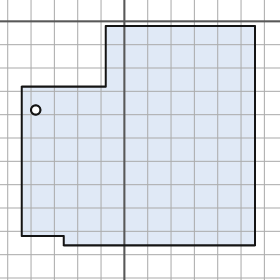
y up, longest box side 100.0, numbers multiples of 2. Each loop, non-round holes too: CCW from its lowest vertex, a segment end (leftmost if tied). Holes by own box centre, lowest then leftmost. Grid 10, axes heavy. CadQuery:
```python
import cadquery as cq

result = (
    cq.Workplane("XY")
    .moveTo(-26.0, -96.0)
    .lineTo(56.0, -96.0)
    .lineTo(56.0, -2.0)
    .lineTo(-8.0, -2.0)
    .lineTo(-8.0, -28.0)
    .lineTo(-44.0, -28.0)
    .lineTo(-44.0, -92.0)
    .lineTo(-26.0, -92.0)
    .close()
    .moveTo(-38.0, -38.0)
    .circle(2.0)
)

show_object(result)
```